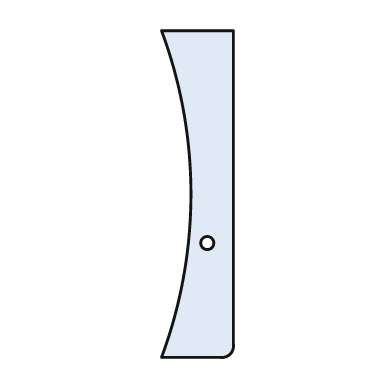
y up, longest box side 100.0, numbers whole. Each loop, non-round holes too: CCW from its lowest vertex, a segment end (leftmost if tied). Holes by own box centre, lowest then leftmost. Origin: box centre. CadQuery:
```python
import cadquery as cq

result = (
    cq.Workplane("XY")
    .moveTo(-11.0, -50.0)
    .lineTo(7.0, -50.0)
    .threePointArc((10.0, -49.0), (11.0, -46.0))
    .lineTo(11.0, 50.0)
    .lineTo(-11.0, 50.0)
    .threePointArc((-2.0, 0.0), (-11.0, -50.0))
    .close()
    .moveTo(3.0, -15.0)
    .circle(2.0)
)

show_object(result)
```